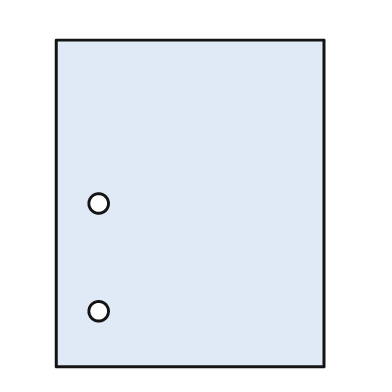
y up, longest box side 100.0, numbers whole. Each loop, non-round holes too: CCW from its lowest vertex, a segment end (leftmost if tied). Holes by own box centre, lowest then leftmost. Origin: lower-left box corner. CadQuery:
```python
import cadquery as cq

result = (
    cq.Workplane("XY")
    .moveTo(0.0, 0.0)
    .lineTo(82.0, 0.0)
    .lineTo(82.0, 100.0)
    .lineTo(0.0, 100.0)
    .close()
    .moveTo(13.0, 17.0)
    .circle(3.0)
    .moveTo(13.0, 50.0)
    .circle(3.0)
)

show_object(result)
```